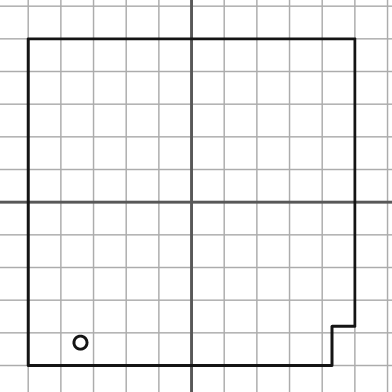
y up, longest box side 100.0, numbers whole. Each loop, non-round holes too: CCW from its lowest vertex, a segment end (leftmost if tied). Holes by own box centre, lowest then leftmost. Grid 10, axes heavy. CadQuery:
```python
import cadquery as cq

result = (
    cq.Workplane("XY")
    .moveTo(-50.0, -50.0)
    .lineTo(43.0, -50.0)
    .lineTo(43.0, -38.0)
    .lineTo(50.0, -38.0)
    .lineTo(50.0, 50.0)
    .lineTo(-50.0, 50.0)
    .close()
    .moveTo(-34.0, -43.0)
    .circle(2.0)
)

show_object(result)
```